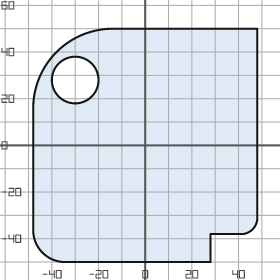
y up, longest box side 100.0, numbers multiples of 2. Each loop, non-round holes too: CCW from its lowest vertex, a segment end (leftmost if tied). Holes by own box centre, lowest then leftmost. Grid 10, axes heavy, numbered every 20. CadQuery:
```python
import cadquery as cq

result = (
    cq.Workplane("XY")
    .moveTo(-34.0, -50.0)
    .lineTo(28.0, -50.0)
    .lineTo(28.0, -38.0)
    .lineTo(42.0, -38.0)
    .threePointArc((46.0, -36.0), (48.0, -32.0))
    .lineTo(48.0, 50.0)
    .lineTo(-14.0, 50.0)
    .threePointArc((-38.0, 40.0), (-48.0, 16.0))
    .lineTo(-48.0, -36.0)
    .threePointArc((-44.0, -46.0), (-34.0, -50.0))
    .close()
    .moveTo(-30.0, 28.0)
    .circle(10.0)
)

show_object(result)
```